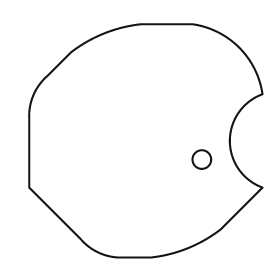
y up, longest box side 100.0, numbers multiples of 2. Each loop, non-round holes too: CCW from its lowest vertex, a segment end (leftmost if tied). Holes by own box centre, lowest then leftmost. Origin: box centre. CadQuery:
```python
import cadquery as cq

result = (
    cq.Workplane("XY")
    .moveTo(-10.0, -50.0)
    .lineTo(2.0, -50.0)
    .threePointArc((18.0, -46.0), (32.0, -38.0))
    .lineTo(50.0, -20.0)
    .threePointArc((36.0, 0.0), (50.0, 20.0))
    .threePointArc((40.0, 40.0), (20.0, 50.0))
    .lineTo(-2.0, 50.0)
    .threePointArc((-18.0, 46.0), (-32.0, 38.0))
    .lineTo(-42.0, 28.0)
    .threePointArc((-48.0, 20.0), (-50.0, 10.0))
    .lineTo(-50.0, -20.0)
    .lineTo(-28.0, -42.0)
    .threePointArc((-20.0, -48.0), (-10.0, -50.0))
    .close()
    .moveTo(24.0, -8.0)
    .circle(4.0)
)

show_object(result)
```